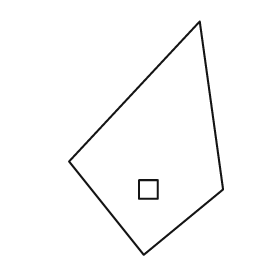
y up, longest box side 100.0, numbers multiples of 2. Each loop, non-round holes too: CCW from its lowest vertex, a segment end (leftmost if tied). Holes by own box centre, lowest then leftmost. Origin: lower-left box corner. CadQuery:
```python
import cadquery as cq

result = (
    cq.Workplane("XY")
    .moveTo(32.0, 0.0)
    .lineTo(66.0, 28.0)
    .lineTo(56.0, 100.0)
    .lineTo(0.0, 40.0)
    .close()
    .moveTo(30.0, 24.0)
    .lineTo(38.0, 24.0)
    .lineTo(38.0, 32.0)
    .lineTo(30.0, 32.0)
    .close()
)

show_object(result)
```